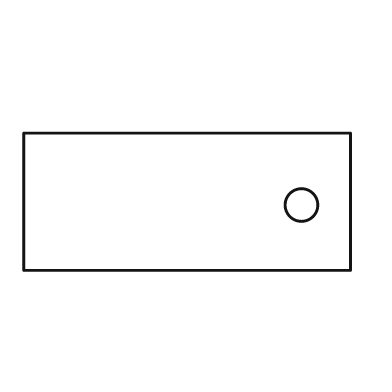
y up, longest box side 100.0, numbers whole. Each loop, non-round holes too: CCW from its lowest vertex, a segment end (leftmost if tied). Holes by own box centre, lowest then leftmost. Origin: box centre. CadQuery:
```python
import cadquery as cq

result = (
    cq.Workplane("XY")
    .moveTo(-50.0, -21.0)
    .lineTo(50.0, -21.0)
    .lineTo(50.0, 21.0)
    .lineTo(-50.0, 21.0)
    .close()
    .moveTo(35.0, -1.0)
    .circle(5.0)
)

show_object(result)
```